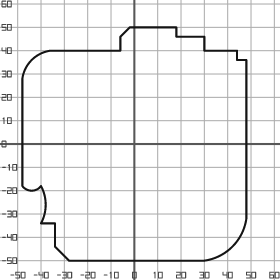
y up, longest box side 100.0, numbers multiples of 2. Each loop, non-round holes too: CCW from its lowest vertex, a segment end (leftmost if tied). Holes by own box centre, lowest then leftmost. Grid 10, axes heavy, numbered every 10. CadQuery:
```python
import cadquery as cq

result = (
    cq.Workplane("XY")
    .moveTo(-28.0, -50.0)
    .lineTo(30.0, -50.0)
    .threePointArc((42.0, -44.0), (48.0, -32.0))
    .lineTo(48.0, 36.0)
    .lineTo(44.0, 36.0)
    .lineTo(44.0, 40.0)
    .lineTo(30.0, 40.0)
    .lineTo(30.0, 46.0)
    .lineTo(18.0, 46.0)
    .lineTo(18.0, 50.0)
    .lineTo(-2.0, 50.0)
    .lineTo(-6.0, 46.0)
    .lineTo(-6.0, 40.0)
    .lineTo(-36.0, 40.0)
    .threePointArc((-44.0, 36.0), (-48.0, 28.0))
    .lineTo(-48.0, -18.0)
    .threePointArc((-44.0, -20.0), (-40.0, -18.0))
    .threePointArc((-38.0, -26.0), (-40.0, -34.0))
    .lineTo(-34.0, -34.0)
    .lineTo(-34.0, -44.0)
    .close()
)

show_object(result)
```